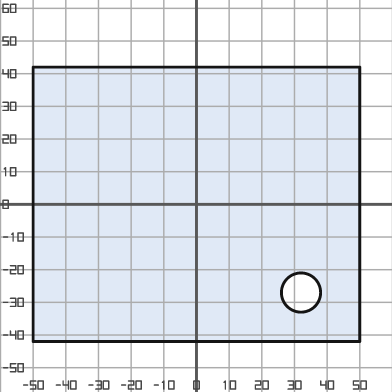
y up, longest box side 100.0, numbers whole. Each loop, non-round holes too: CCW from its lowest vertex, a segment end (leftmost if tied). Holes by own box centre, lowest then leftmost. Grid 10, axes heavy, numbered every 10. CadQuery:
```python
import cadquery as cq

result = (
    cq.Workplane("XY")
    .moveTo(-50.0, -42.0)
    .lineTo(50.0, -42.0)
    .lineTo(50.0, 42.0)
    .lineTo(-50.0, 42.0)
    .close()
    .moveTo(32.0, -27.0)
    .circle(6.0)
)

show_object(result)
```